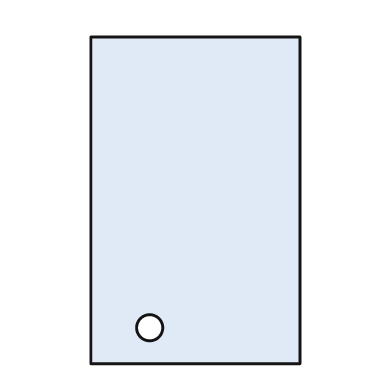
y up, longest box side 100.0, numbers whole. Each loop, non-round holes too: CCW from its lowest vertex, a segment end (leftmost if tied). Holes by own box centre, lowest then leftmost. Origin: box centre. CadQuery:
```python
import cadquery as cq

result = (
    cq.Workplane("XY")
    .moveTo(-32.0, -50.0)
    .lineTo(32.0, -50.0)
    .lineTo(32.0, 50.0)
    .lineTo(-32.0, 50.0)
    .close()
    .moveTo(-14.0, -39.0)
    .circle(4.0)
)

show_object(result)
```